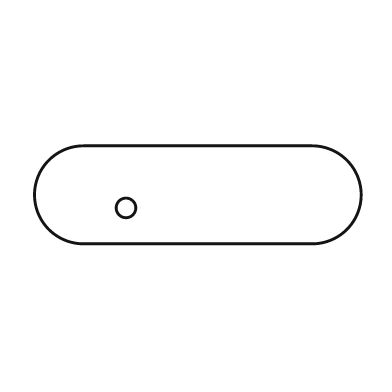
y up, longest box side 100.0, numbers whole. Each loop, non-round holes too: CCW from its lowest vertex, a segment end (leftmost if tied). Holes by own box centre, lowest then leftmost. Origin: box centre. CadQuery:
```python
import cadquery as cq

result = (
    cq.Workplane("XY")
    .moveTo(-35.0, -15.0)
    .lineTo(35.0, -15.0)
    .threePointArc((50.0, 0.0), (35.0, 15.0))
    .lineTo(-35.0, 15.0)
    .threePointArc((-50.0, 0.0), (-35.0, -15.0))
    .close()
    .moveTo(-22.0, -4.0)
    .circle(3.0)
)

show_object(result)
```